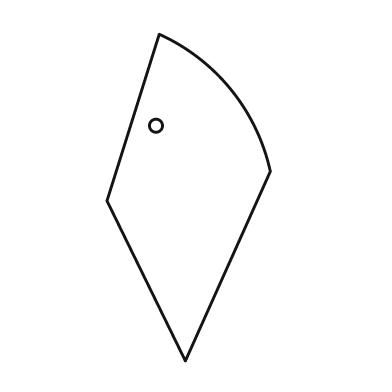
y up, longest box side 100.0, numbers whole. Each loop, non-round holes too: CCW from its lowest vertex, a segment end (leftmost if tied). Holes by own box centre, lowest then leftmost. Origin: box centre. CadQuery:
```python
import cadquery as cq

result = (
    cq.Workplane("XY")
    .moveTo(-1.0, -50.0)
    .lineTo(25.0, 8.0)
    .threePointArc((13.0, 33.0), (-9.0, 50.0))
    .lineTo(-25.0, -1.0)
    .close()
    .moveTo(-10.0, 22.0)
    .circle(2.0)
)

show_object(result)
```